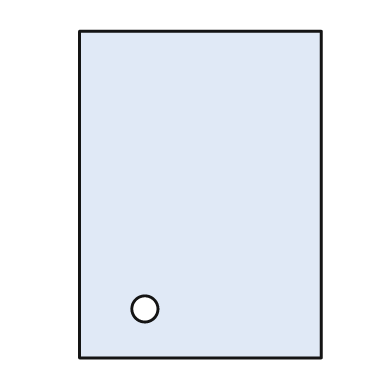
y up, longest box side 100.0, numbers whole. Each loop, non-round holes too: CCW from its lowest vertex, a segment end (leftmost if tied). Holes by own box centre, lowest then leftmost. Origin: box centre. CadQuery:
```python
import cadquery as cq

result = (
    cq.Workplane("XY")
    .moveTo(-37.0, -50.0)
    .lineTo(37.0, -50.0)
    .lineTo(37.0, 50.0)
    .lineTo(-37.0, 50.0)
    .close()
    .moveTo(-17.0, -35.0)
    .circle(4.0)
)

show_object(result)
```